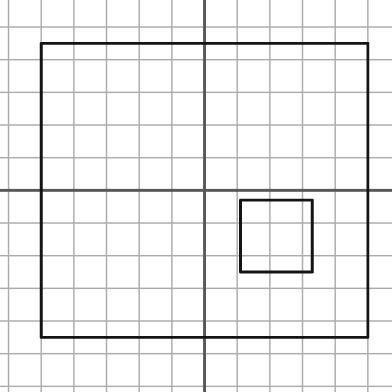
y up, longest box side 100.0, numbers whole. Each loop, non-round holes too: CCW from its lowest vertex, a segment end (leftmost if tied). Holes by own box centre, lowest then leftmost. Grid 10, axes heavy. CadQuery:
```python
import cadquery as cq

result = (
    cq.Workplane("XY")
    .moveTo(-50.0, -45.0)
    .lineTo(50.0, -45.0)
    .lineTo(50.0, 45.0)
    .lineTo(-50.0, 45.0)
    .close()
    .moveTo(11.0, -25.0)
    .lineTo(33.0, -25.0)
    .lineTo(33.0, -3.0)
    .lineTo(11.0, -3.0)
    .close()
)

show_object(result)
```